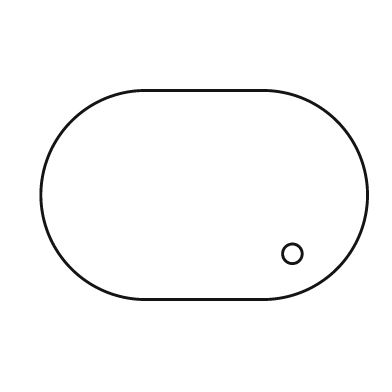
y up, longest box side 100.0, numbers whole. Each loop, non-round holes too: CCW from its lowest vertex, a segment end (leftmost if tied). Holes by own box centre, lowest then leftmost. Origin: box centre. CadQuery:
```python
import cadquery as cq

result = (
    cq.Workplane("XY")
    .moveTo(-18.0, -32.0)
    .lineTo(18.0, -32.0)
    .threePointArc((50.0, 0.0), (18.0, 32.0))
    .lineTo(-18.0, 32.0)
    .threePointArc((-50.0, 0.0), (-18.0, -32.0))
    .close()
    .moveTo(27.0, -18.0)
    .circle(3.0)
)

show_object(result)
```